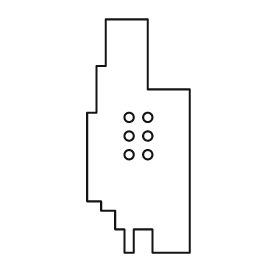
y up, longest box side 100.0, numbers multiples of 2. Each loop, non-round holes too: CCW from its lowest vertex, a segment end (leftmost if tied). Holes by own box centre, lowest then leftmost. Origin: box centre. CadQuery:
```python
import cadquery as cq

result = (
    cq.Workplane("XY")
    .moveTo(-6.0, -50.0)
    .lineTo(-2.0, -50.0)
    .lineTo(-2.0, -40.0)
    .lineTo(6.0, -40.0)
    .lineTo(6.0, -50.0)
    .lineTo(22.0, -50.0)
    .lineTo(22.0, 20.0)
    .lineTo(4.0, 20.0)
    .lineTo(4.0, 50.0)
    .lineTo(-14.0, 50.0)
    .lineTo(-14.0, 30.0)
    .lineTo(-18.0, 30.0)
    .lineTo(-18.0, 10.0)
    .lineTo(-22.0, 10.0)
    .lineTo(-22.0, -28.0)
    .lineTo(-16.0, -28.0)
    .lineTo(-16.0, -32.0)
    .lineTo(-10.0, -32.0)
    .lineTo(-10.0, -40.0)
    .lineTo(-6.0, -40.0)
    .close()
    .moveTo(-4.0, -8.0)
    .circle(2.0)
    .moveTo(4.0, -8.0)
    .circle(2.0)
    .moveTo(-4.0, 0.0)
    .circle(2.0)
    .moveTo(4.0, 0.0)
    .circle(2.0)
    .moveTo(-4.0, 8.0)
    .circle(2.0)
    .moveTo(4.0, 8.0)
    .circle(2.0)
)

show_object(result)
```